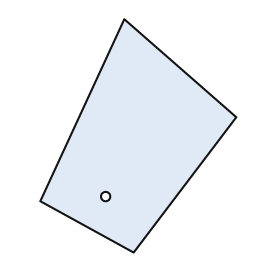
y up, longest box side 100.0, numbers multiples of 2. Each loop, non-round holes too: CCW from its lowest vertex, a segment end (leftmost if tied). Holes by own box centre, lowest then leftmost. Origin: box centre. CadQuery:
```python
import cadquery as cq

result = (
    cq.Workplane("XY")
    .moveTo(-2.0, -50.0)
    .lineTo(42.0, 8.0)
    .lineTo(-6.0, 50.0)
    .lineTo(-42.0, -28.0)
    .close()
    .moveTo(-14.0, -26.0)
    .circle(2.0)
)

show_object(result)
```